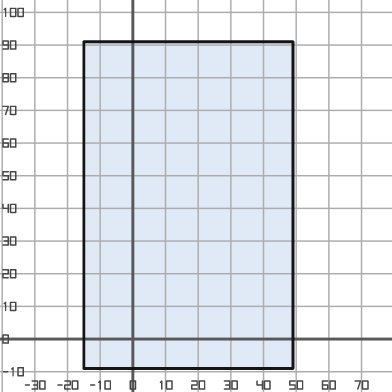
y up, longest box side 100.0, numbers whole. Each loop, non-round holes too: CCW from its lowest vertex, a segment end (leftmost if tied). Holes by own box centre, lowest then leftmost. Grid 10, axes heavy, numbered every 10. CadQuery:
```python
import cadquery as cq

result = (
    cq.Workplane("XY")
    .moveTo(-15.0, -9.0)
    .lineTo(49.0, -9.0)
    .lineTo(49.0, 91.0)
    .lineTo(-15.0, 91.0)
    .close()
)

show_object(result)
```